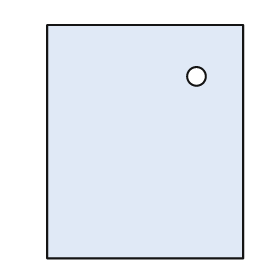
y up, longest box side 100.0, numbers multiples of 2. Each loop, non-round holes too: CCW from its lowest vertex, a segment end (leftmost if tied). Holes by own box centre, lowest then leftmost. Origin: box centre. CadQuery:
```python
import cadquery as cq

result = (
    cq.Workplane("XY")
    .moveTo(-42.0, -50.0)
    .lineTo(42.0, -50.0)
    .lineTo(42.0, 50.0)
    .lineTo(-42.0, 50.0)
    .close()
    .moveTo(22.0, 28.0)
    .circle(4.0)
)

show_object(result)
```